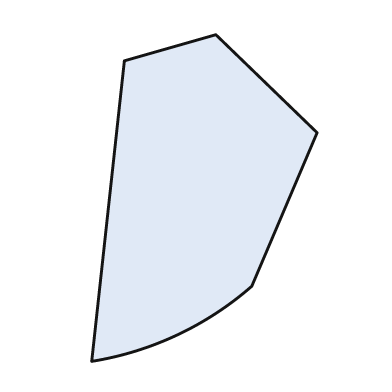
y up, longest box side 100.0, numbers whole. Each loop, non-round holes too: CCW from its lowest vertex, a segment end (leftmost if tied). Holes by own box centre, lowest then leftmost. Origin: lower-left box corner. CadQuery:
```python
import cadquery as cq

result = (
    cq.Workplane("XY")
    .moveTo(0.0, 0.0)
    .threePointArc((26.0, 8.0), (49.0, 23.0))
    .lineTo(69.0, 70.0)
    .lineTo(38.0, 100.0)
    .lineTo(10.0, 92.0)
    .close()
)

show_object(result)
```